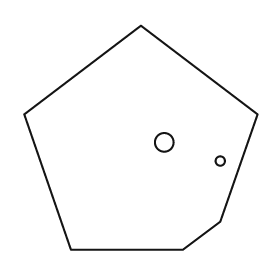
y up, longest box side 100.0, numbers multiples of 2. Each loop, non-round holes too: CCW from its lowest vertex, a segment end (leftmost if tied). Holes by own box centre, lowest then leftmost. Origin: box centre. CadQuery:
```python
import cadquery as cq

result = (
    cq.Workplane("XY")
    .moveTo(-30.0, -48.0)
    .lineTo(18.0, -48.0)
    .lineTo(34.0, -36.0)
    .lineTo(50.0, 10.0)
    .lineTo(0.0, 48.0)
    .lineTo(-50.0, 10.0)
    .close()
    .moveTo(34.0, -10.0)
    .circle(2.0)
    .moveTo(10.0, -2.0)
    .circle(4.0)
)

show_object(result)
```